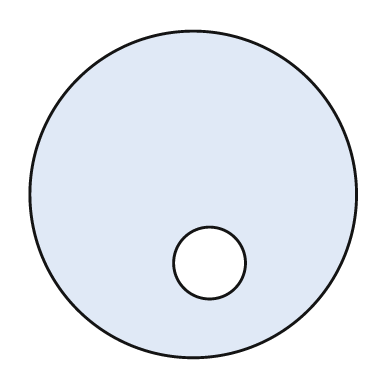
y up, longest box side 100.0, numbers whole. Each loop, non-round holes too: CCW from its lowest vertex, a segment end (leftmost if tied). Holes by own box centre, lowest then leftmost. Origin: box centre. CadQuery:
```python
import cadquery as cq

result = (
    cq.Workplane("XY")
    .moveTo(0.0, 0.0)
    .circle(50.0)
    .moveTo(5.0, -21.0)
    .circle(11.0)
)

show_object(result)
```